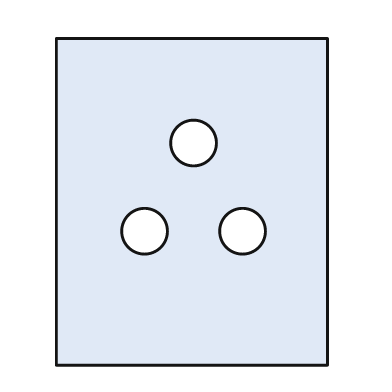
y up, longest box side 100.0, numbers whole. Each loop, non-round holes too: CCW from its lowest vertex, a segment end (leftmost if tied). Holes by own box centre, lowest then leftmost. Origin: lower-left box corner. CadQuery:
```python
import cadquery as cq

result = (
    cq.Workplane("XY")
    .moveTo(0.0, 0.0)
    .lineTo(83.0, 0.0)
    .lineTo(83.0, 100.0)
    .lineTo(0.0, 100.0)
    .close()
    .moveTo(27.0, 41.0)
    .circle(7.0)
    .moveTo(57.0, 41.0)
    .circle(7.0)
    .moveTo(42.0, 68.0)
    .circle(7.0)
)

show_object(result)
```